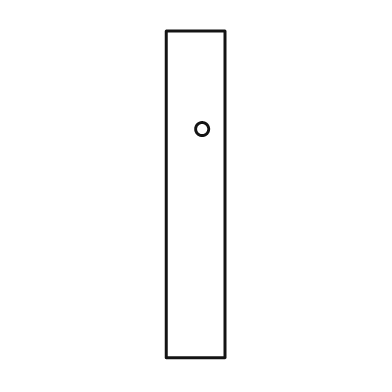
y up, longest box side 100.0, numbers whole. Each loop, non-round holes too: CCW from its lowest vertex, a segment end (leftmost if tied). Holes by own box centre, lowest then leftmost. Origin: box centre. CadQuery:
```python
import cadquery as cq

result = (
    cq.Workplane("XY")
    .moveTo(-9.0, -50.0)
    .lineTo(9.0, -50.0)
    .lineTo(9.0, 50.0)
    .lineTo(-9.0, 50.0)
    .close()
    .moveTo(2.0, 20.0)
    .circle(2.0)
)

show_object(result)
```